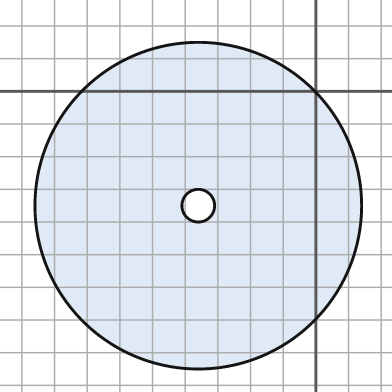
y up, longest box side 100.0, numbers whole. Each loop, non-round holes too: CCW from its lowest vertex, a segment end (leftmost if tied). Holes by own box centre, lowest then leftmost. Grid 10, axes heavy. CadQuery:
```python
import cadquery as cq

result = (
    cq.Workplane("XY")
    .moveTo(-36.0, -35.0)
    .circle(50.0)
    .moveTo(-36.0, -35.0)
    .circle(5.0)
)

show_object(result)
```